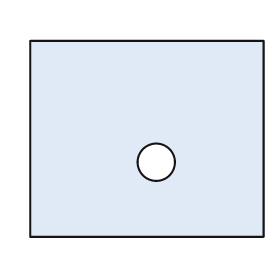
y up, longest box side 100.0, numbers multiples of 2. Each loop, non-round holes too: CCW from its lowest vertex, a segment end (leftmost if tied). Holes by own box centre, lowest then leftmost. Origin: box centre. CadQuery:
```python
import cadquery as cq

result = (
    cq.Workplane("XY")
    .moveTo(-50.0, -42.0)
    .lineTo(50.0, -42.0)
    .lineTo(50.0, 42.0)
    .lineTo(-50.0, 42.0)
    .close()
    .moveTo(4.0, -10.0)
    .circle(8.0)
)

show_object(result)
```